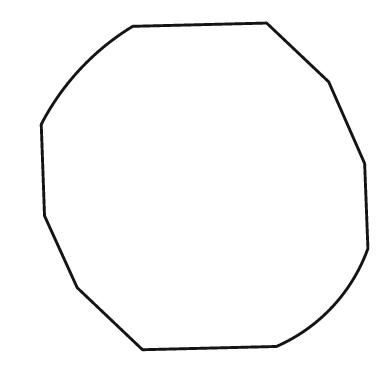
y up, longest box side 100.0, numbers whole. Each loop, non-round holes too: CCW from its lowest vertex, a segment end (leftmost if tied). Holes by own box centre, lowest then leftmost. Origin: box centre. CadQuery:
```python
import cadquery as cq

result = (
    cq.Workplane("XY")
    .moveTo(-19.0, -50.0)
    .lineTo(22.0, -49.0)
    .threePointArc((39.0, -37.0), (50.0, -19.0))
    .lineTo(49.0, 7.0)
    .lineTo(38.0, 32.0)
    .lineTo(19.0, 50.0)
    .lineTo(-22.0, 49.0)
    .threePointArc((-38.0, 36.0), (-50.0, 19.0))
    .lineTo(-49.0, -9.0)
    .lineTo(-39.0, -31.0)
    .close()
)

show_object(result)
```